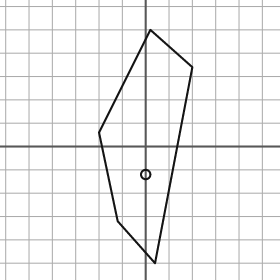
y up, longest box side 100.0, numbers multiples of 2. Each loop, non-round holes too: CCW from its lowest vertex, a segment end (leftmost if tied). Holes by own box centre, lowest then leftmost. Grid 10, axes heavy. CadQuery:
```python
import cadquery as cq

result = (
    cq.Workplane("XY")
    .moveTo(4.0, -50.0)
    .lineTo(20.0, 34.0)
    .lineTo(2.0, 50.0)
    .lineTo(-20.0, 6.0)
    .lineTo(-12.0, -32.0)
    .close()
    .moveTo(0.0, -12.0)
    .circle(2.0)
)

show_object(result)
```